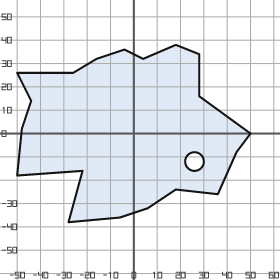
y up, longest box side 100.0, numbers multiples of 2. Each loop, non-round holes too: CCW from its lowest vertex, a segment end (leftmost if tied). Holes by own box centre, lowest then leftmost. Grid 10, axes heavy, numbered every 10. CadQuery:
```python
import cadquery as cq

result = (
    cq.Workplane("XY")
    .moveTo(-28.0, -38.0)
    .lineTo(-6.0, -36.0)
    .lineTo(6.0, -32.0)
    .lineTo(18.0, -24.0)
    .lineTo(36.0, -26.0)
    .lineTo(44.0, -8.0)
    .lineTo(50.0, 0.0)
    .lineTo(28.0, 16.0)
    .lineTo(28.0, 34.0)
    .lineTo(18.0, 38.0)
    .lineTo(4.0, 32.0)
    .lineTo(-4.0, 36.0)
    .lineTo(-16.0, 32.0)
    .lineTo(-26.0, 26.0)
    .lineTo(-50.0, 26.0)
    .lineTo(-44.0, 14.0)
    .lineTo(-48.0, 2.0)
    .lineTo(-50.0, -18.0)
    .lineTo(-22.0, -16.0)
    .close()
    .moveTo(26.0, -12.0)
    .circle(4.0)
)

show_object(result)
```